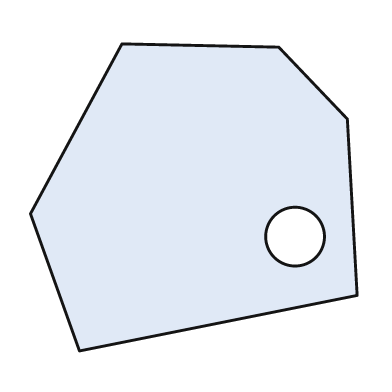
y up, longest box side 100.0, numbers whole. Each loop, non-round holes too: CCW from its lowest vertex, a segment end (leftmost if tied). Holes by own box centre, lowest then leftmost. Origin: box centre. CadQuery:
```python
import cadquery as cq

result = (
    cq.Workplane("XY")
    .moveTo(-35.0, -47.0)
    .lineTo(50.0, -30.0)
    .lineTo(47.0, 24.0)
    .lineTo(26.0, 46.0)
    .lineTo(-22.0, 47.0)
    .lineTo(-50.0, -5.0)
    .close()
    .moveTo(31.0, -12.0)
    .circle(9.0)
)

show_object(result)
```